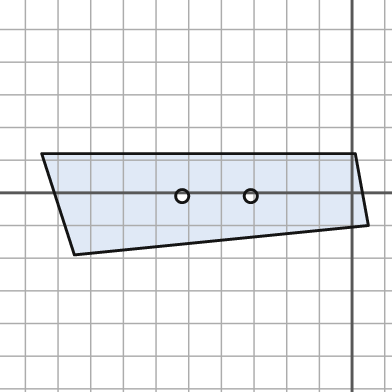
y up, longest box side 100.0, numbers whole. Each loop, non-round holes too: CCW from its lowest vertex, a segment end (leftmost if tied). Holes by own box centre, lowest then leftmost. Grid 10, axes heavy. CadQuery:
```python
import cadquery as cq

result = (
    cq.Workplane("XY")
    .moveTo(-85.0, -19.0)
    .lineTo(5.0, -10.0)
    .lineTo(1.0, 12.0)
    .lineTo(-95.0, 12.0)
    .close()
    .moveTo(-52.0, -1.0)
    .circle(2.0)
    .moveTo(-31.0, -1.0)
    .circle(2.0)
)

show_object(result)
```